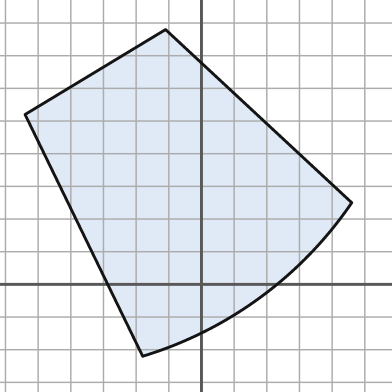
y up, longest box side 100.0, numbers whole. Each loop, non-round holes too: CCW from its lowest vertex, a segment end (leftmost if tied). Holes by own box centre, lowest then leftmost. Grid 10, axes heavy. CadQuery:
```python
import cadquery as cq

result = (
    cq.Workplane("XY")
    .moveTo(-18.0, -22.0)
    .threePointArc((18.0, -4.0), (46.0, 25.0))
    .lineTo(-11.0, 78.0)
    .lineTo(-54.0, 52.0)
    .close()
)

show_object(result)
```